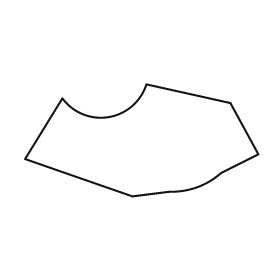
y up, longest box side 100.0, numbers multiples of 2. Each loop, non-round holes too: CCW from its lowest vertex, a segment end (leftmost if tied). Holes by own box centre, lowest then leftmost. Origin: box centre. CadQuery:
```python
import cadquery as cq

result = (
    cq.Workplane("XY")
    .moveTo(-4.0, -24.0)
    .lineTo(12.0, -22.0)
    .threePointArc((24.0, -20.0), (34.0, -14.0))
    .lineTo(50.0, -6.0)
    .lineTo(38.0, 16.0)
    .lineTo(2.0, 24.0)
    .threePointArc((-14.0, 10.0), (-34.0, 18.0))
    .lineTo(-50.0, -8.0)
    .close()
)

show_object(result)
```